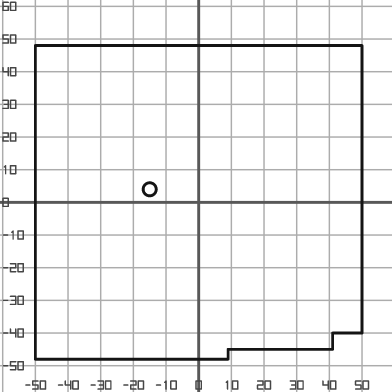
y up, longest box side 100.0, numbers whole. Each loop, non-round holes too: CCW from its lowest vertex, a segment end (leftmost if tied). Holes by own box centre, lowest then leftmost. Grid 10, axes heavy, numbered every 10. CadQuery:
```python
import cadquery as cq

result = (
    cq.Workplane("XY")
    .moveTo(-50.0, -48.0)
    .lineTo(9.0, -48.0)
    .lineTo(9.0, -45.0)
    .lineTo(41.0, -45.0)
    .lineTo(41.0, -40.0)
    .lineTo(50.0, -40.0)
    .lineTo(50.0, 48.0)
    .lineTo(-50.0, 48.0)
    .close()
    .moveTo(-15.0, 4.0)
    .circle(2.0)
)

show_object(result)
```